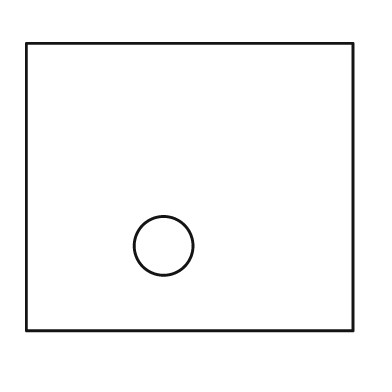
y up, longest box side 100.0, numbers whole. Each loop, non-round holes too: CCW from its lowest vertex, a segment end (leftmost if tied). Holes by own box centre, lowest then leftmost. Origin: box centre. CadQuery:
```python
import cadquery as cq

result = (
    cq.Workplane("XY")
    .moveTo(-50.0, -44.0)
    .lineTo(50.0, -44.0)
    .lineTo(50.0, 44.0)
    .lineTo(-50.0, 44.0)
    .close()
    .moveTo(-8.0, -18.0)
    .circle(9.0)
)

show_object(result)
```